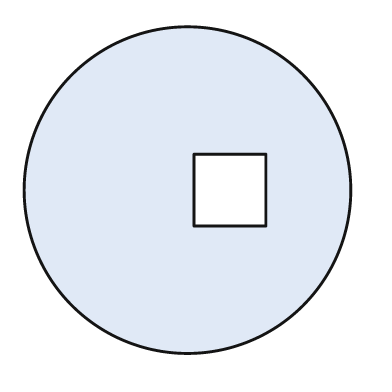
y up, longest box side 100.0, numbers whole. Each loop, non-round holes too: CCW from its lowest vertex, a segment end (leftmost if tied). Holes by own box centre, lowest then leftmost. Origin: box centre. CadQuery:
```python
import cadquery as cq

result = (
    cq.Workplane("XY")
    .moveTo(0.0, 0.0)
    .circle(50.0)
    .moveTo(2.0, -11.0)
    .lineTo(24.0, -11.0)
    .lineTo(24.0, 11.0)
    .lineTo(2.0, 11.0)
    .close()
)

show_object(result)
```